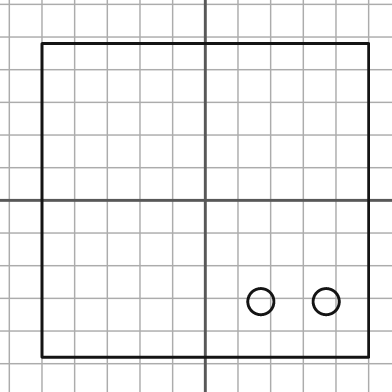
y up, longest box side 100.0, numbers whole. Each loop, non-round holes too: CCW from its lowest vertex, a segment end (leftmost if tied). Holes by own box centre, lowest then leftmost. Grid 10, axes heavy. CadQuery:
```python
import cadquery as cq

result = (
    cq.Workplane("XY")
    .moveTo(-50.0, -48.0)
    .lineTo(50.0, -48.0)
    .lineTo(50.0, 48.0)
    .lineTo(-50.0, 48.0)
    .close()
    .moveTo(17.0, -31.0)
    .circle(4.0)
    .moveTo(37.0, -31.0)
    .circle(4.0)
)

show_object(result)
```